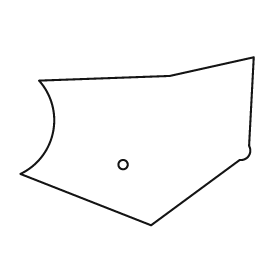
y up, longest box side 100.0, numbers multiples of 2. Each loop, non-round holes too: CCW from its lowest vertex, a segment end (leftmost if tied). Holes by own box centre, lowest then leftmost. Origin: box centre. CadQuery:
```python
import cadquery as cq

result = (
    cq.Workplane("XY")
    .moveTo(6.0, -36.0)
    .lineTo(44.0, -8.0)
    .threePointArc((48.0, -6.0), (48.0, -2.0))
    .lineTo(50.0, 36.0)
    .lineTo(14.0, 28.0)
    .lineTo(-42.0, 26.0)
    .threePointArc((-36.0, 4.0), (-50.0, -14.0))
    .close()
    .moveTo(-6.0, -10.0)
    .circle(2.0)
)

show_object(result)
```